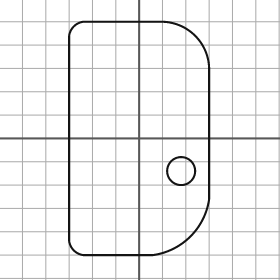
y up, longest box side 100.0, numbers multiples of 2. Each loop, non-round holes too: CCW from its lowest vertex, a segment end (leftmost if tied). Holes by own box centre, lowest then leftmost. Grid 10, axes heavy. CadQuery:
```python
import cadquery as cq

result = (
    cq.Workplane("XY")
    .moveTo(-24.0, -50.0)
    .lineTo(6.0, -50.0)
    .threePointArc((22.0, -42.0), (30.0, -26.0))
    .lineTo(30.0, 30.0)
    .threePointArc((24.0, 44.0), (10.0, 50.0))
    .lineTo(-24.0, 50.0)
    .threePointArc((-28.0, 48.0), (-30.0, 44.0))
    .lineTo(-30.0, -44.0)
    .threePointArc((-28.0, -48.0), (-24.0, -50.0))
    .close()
    .moveTo(18.0, -14.0)
    .circle(6.0)
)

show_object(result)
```